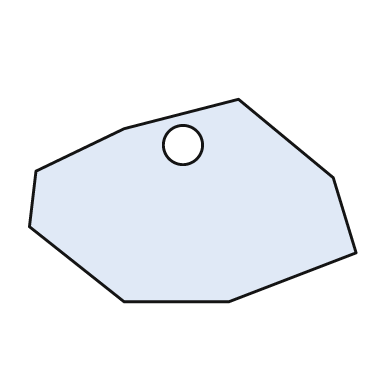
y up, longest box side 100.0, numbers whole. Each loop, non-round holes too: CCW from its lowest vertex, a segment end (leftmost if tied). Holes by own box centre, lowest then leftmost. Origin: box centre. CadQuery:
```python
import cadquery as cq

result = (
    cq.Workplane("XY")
    .moveTo(-21.0, -31.0)
    .lineTo(11.0, -31.0)
    .lineTo(50.0, -16.0)
    .lineTo(43.0, 7.0)
    .lineTo(14.0, 31.0)
    .lineTo(-21.0, 22.0)
    .lineTo(-48.0, 9.0)
    .lineTo(-50.0, -8.0)
    .close()
    .moveTo(-3.0, 17.0)
    .circle(6.0)
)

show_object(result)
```